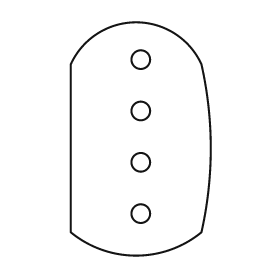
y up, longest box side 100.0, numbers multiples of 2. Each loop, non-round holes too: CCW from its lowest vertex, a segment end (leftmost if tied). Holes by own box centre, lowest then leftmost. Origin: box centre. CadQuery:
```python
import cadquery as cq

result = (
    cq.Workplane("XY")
    .moveTo(-30.0, -40.0)
    .threePointArc((-2.0, -50.0), (26.0, -40.0))
    .threePointArc((30.0, -4.0), (26.0, 32.0))
    .threePointArc((-2.0, 50.0), (-30.0, 32.0))
    .close()
    .moveTo(0.0, -32.0)
    .circle(4.0)
    .moveTo(0.0, -10.0)
    .circle(4.0)
    .moveTo(0.0, 12.0)
    .circle(4.0)
    .moveTo(0.0, 34.0)
    .circle(4.0)
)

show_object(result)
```